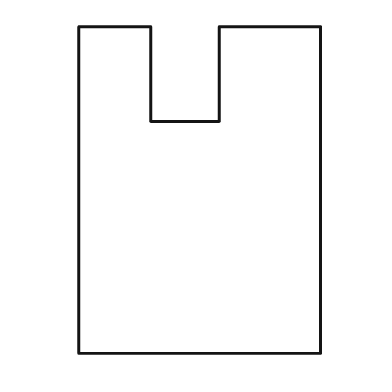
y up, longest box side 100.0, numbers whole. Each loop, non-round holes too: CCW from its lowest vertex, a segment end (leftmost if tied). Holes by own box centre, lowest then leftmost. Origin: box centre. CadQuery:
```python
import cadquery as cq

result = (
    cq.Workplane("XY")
    .moveTo(-37.0, -50.0)
    .lineTo(37.0, -50.0)
    .lineTo(37.0, 50.0)
    .lineTo(6.0, 50.0)
    .lineTo(6.0, 21.0)
    .lineTo(-15.0, 21.0)
    .lineTo(-15.0, 50.0)
    .lineTo(-37.0, 50.0)
    .close()
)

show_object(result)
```